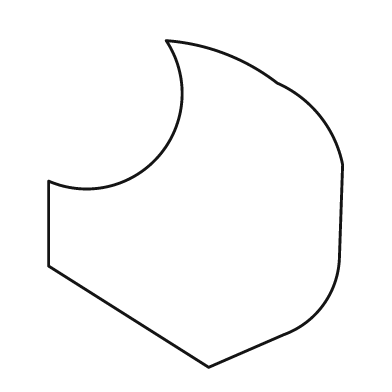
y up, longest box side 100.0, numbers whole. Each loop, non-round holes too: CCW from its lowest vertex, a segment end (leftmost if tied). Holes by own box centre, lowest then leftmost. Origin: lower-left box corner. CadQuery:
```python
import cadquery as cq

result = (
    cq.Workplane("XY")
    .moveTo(49.0, 0.0)
    .lineTo(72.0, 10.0)
    .threePointArc((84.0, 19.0), (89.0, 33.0))
    .lineTo(90.0, 62.0)
    .threePointArc((83.0, 77.0), (70.0, 87.0))
    .threePointArc((54.0, 96.0), (36.0, 100.0))
    .threePointArc((34.0, 65.0), (0.0, 57.0))
    .lineTo(0.0, 31.0)
    .close()
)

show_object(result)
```